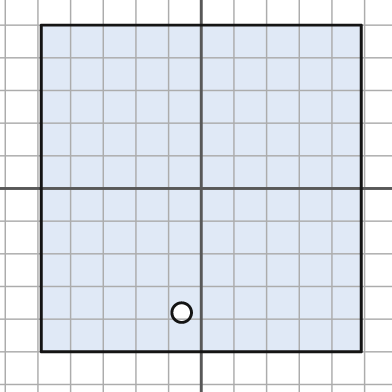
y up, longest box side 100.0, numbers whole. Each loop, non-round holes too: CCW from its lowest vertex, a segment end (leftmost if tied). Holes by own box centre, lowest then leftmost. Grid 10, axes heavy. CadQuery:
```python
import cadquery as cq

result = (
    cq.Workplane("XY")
    .moveTo(-49.0, -50.0)
    .lineTo(49.0, -50.0)
    .lineTo(49.0, 50.0)
    .lineTo(-49.0, 50.0)
    .close()
    .moveTo(-6.0, -38.0)
    .circle(3.0)
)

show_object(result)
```